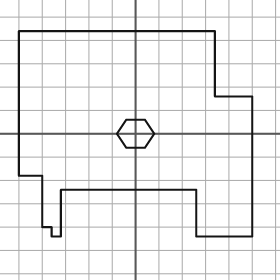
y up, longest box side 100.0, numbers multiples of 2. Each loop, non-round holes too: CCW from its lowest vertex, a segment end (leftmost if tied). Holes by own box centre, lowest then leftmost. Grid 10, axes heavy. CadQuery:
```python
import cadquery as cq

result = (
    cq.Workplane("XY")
    .moveTo(-36.0, -44.0)
    .lineTo(-32.0, -44.0)
    .lineTo(-32.0, -24.0)
    .lineTo(26.0, -24.0)
    .lineTo(26.0, -44.0)
    .lineTo(50.0, -44.0)
    .lineTo(50.0, 16.0)
    .lineTo(34.0, 16.0)
    .lineTo(34.0, 44.0)
    .lineTo(-50.0, 44.0)
    .lineTo(-50.0, -18.0)
    .lineTo(-40.0, -18.0)
    .lineTo(-40.0, -40.0)
    .lineTo(-36.0, -40.0)
    .close()
    .moveTo(-4.0, -6.0)
    .lineTo(4.0, -6.0)
    .lineTo(8.0, 0.0)
    .lineTo(4.0, 6.0)
    .lineTo(-4.0, 6.0)
    .lineTo(-8.0, 0.0)
    .close()
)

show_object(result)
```